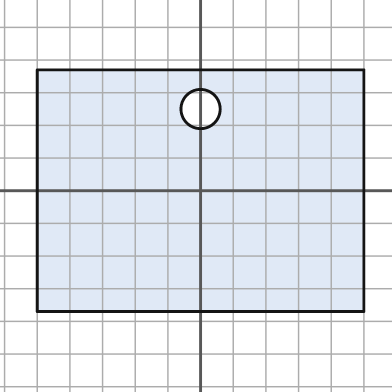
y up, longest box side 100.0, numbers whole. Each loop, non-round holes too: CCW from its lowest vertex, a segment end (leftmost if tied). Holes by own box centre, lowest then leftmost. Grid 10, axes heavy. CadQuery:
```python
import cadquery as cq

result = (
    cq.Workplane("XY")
    .moveTo(-50.0, -37.0)
    .lineTo(50.0, -37.0)
    .lineTo(50.0, 37.0)
    .lineTo(-50.0, 37.0)
    .close()
    .moveTo(0.0, 25.0)
    .circle(6.0)
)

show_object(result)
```